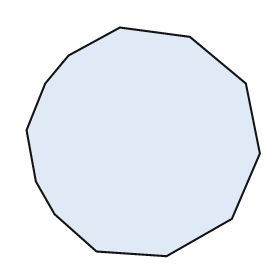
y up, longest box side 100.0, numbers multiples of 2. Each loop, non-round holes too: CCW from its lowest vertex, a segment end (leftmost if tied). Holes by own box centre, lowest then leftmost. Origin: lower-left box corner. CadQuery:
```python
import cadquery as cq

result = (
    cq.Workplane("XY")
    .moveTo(60.0, 0.0)
    .lineTo(88.0, 16.0)
    .lineTo(100.0, 44.0)
    .lineTo(94.0, 74.0)
    .lineTo(70.0, 94.0)
    .lineTo(40.0, 98.0)
    .lineTo(18.0, 86.0)
    .lineTo(8.0, 74.0)
    .lineTo(0.0, 54.0)
    .lineTo(4.0, 32.0)
    .lineTo(12.0, 18.0)
    .lineTo(30.0, 2.0)
    .close()
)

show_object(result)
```